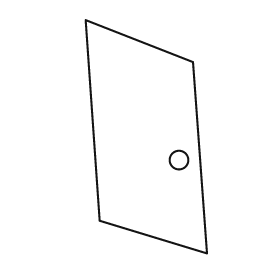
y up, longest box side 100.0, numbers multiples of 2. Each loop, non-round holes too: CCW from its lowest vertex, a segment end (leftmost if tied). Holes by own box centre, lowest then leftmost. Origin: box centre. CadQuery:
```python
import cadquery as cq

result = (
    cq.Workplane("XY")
    .moveTo(26.0, -50.0)
    .lineTo(20.0, 32.0)
    .lineTo(-26.0, 50.0)
    .lineTo(-20.0, -36.0)
    .close()
    .moveTo(14.0, -10.0)
    .circle(4.0)
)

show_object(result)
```